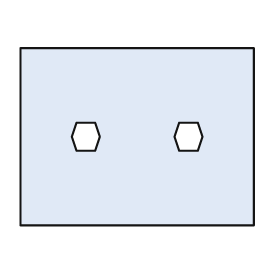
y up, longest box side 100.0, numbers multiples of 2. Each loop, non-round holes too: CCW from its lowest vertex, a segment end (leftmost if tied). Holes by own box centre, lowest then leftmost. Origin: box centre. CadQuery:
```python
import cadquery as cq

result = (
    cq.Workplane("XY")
    .moveTo(-50.0, -38.0)
    .lineTo(50.0, -38.0)
    .lineTo(50.0, 38.0)
    .lineTo(-50.0, 38.0)
    .close()
    .moveTo(-26.0, -6.0)
    .lineTo(-18.0, -6.0)
    .lineTo(-16.0, 0.0)
    .lineTo(-18.0, 6.0)
    .lineTo(-26.0, 6.0)
    .lineTo(-28.0, 0.0)
    .close()
    .moveTo(18.0, -6.0)
    .lineTo(26.0, -6.0)
    .lineTo(28.0, 0.0)
    .lineTo(26.0, 6.0)
    .lineTo(18.0, 6.0)
    .lineTo(16.0, 0.0)
    .close()
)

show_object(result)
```